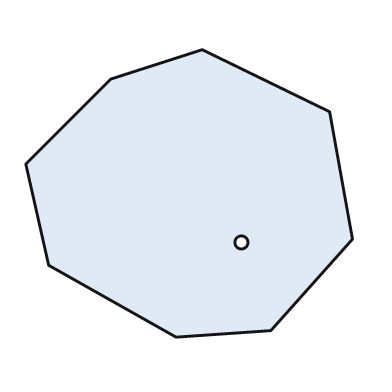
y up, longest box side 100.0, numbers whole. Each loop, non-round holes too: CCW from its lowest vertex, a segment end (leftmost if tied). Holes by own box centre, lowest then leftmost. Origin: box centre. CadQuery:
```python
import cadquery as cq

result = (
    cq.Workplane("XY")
    .moveTo(-4.0, -44.0)
    .lineTo(25.0, -42.0)
    .lineTo(50.0, -14.0)
    .lineTo(43.0, 25.0)
    .lineTo(4.0, 44.0)
    .lineTo(-24.0, 35.0)
    .lineTo(-50.0, 9.0)
    .lineTo(-43.0, -22.0)
    .close()
    .moveTo(16.0, -15.0)
    .circle(2.0)
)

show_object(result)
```